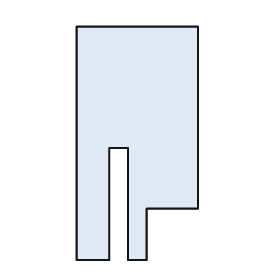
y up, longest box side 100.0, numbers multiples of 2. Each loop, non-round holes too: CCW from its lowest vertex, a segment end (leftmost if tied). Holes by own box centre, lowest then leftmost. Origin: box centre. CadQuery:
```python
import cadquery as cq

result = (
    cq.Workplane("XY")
    .moveTo(-26.0, -50.0)
    .lineTo(-12.0, -50.0)
    .lineTo(-12.0, -2.0)
    .lineTo(-4.0, -2.0)
    .lineTo(-4.0, -50.0)
    .lineTo(4.0, -50.0)
    .lineTo(4.0, -28.0)
    .lineTo(26.0, -28.0)
    .lineTo(26.0, 50.0)
    .lineTo(-26.0, 50.0)
    .close()
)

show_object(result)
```